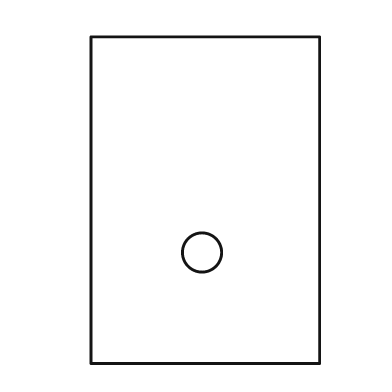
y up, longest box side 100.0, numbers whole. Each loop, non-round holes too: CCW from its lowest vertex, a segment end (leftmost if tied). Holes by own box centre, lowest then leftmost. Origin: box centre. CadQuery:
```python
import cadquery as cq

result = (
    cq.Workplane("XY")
    .moveTo(-35.0, -50.0)
    .lineTo(35.0, -50.0)
    .lineTo(35.0, 50.0)
    .lineTo(-35.0, 50.0)
    .close()
    .moveTo(-1.0, -16.0)
    .circle(6.0)
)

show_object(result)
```